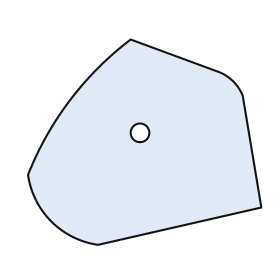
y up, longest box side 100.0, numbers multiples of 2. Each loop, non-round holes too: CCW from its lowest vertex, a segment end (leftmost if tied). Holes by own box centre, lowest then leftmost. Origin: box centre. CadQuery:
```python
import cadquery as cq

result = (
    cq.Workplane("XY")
    .moveTo(-20.0, -44.0)
    .lineTo(50.0, -28.0)
    .lineTo(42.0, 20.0)
    .threePointArc((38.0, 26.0), (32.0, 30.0))
    .lineTo(-6.0, 44.0)
    .threePointArc((-32.0, 18.0), (-50.0, -14.0))
    .threePointArc((-40.0, -34.0), (-20.0, -44.0))
    .close()
    .moveTo(-2.0, 4.0)
    .circle(4.0)
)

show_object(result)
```